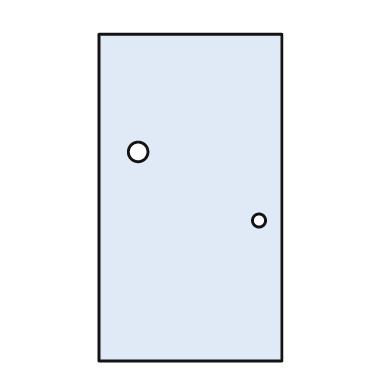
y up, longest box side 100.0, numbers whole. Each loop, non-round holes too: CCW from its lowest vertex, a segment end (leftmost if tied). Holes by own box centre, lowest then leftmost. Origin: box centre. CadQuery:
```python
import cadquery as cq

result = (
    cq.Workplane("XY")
    .moveTo(-28.0, -50.0)
    .lineTo(28.0, -50.0)
    .lineTo(28.0, 50.0)
    .lineTo(-28.0, 50.0)
    .close()
    .moveTo(21.0, -7.0)
    .circle(2.0)
    .moveTo(-16.0, 14.0)
    .circle(3.0)
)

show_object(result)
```